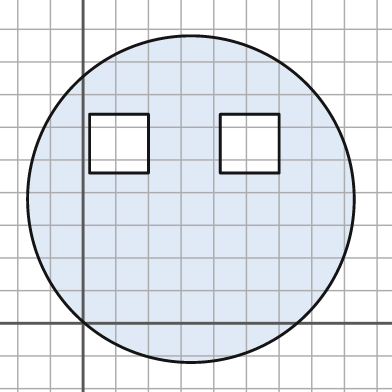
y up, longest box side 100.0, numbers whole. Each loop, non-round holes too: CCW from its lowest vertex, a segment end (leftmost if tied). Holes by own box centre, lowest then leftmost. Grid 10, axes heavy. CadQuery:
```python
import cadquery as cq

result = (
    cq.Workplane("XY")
    .moveTo(33.0, 38.0)
    .circle(50.0)
    .moveTo(2.0, 46.0)
    .lineTo(20.0, 46.0)
    .lineTo(20.0, 64.0)
    .lineTo(2.0, 64.0)
    .close()
    .moveTo(42.0, 46.0)
    .lineTo(60.0, 46.0)
    .lineTo(60.0, 64.0)
    .lineTo(42.0, 64.0)
    .close()
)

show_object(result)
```